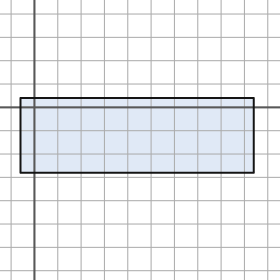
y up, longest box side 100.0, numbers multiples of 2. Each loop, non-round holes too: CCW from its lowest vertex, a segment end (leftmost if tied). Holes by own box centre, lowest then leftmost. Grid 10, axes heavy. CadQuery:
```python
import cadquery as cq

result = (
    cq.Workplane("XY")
    .moveTo(-6.0, -28.0)
    .lineTo(94.0, -28.0)
    .lineTo(94.0, 4.0)
    .lineTo(-6.0, 4.0)
    .close()
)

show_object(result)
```